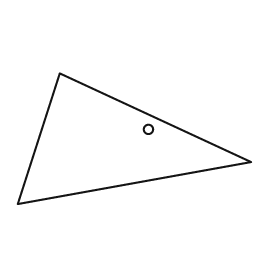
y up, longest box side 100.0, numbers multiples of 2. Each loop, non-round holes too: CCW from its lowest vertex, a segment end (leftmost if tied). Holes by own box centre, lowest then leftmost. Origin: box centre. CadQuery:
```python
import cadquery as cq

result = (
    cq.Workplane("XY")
    .moveTo(-50.0, -28.0)
    .lineTo(50.0, -10.0)
    .lineTo(-32.0, 28.0)
    .close()
    .moveTo(6.0, 4.0)
    .circle(2.0)
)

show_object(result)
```